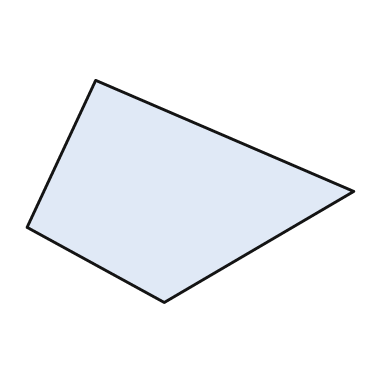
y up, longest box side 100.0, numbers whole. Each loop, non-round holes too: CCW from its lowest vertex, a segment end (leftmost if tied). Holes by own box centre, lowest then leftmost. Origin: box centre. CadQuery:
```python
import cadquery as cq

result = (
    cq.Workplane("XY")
    .moveTo(-8.0, -34.0)
    .lineTo(50.0, 0.0)
    .lineTo(-29.0, 34.0)
    .lineTo(-50.0, -11.0)
    .close()
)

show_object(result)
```